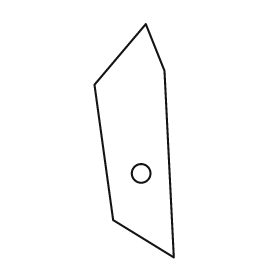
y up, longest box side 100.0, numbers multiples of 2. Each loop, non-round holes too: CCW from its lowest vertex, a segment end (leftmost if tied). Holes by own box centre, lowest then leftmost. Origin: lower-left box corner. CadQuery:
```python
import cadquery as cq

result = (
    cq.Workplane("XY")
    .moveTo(34.0, 0.0)
    .lineTo(30.0, 80.0)
    .lineTo(22.0, 100.0)
    .lineTo(0.0, 74.0)
    .lineTo(8.0, 16.0)
    .close()
    .moveTo(20.0, 36.0)
    .circle(4.0)
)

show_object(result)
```